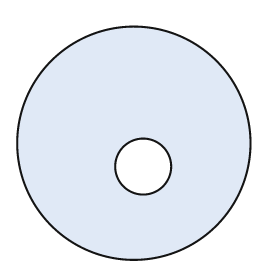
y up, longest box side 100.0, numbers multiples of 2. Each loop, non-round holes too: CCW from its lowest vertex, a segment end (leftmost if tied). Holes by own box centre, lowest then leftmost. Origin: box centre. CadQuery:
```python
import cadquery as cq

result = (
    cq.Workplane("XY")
    .moveTo(0.0, 0.0)
    .circle(50.0)
    .moveTo(4.0, -10.0)
    .circle(12.0)
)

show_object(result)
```